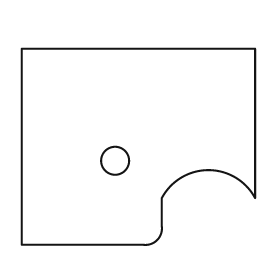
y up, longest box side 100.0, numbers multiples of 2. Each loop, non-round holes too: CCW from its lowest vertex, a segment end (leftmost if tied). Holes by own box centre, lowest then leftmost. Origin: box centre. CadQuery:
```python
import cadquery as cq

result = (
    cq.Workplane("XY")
    .moveTo(-50.0, -42.0)
    .lineTo(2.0, -42.0)
    .threePointArc((8.0, -40.0), (10.0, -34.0))
    .lineTo(10.0, -22.0)
    .threePointArc((30.0, -10.0), (50.0, -22.0))
    .lineTo(50.0, 42.0)
    .lineTo(-50.0, 42.0)
    .close()
    .moveTo(-10.0, -6.0)
    .circle(6.0)
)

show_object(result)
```